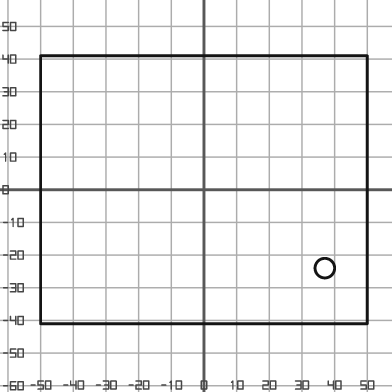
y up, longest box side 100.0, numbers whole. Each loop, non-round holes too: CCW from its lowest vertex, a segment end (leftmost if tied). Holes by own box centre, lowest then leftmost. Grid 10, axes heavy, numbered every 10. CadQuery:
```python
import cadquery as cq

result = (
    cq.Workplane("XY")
    .moveTo(-50.0, -41.0)
    .lineTo(50.0, -41.0)
    .lineTo(50.0, 41.0)
    .lineTo(-50.0, 41.0)
    .close()
    .moveTo(37.0, -24.0)
    .circle(3.0)
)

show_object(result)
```